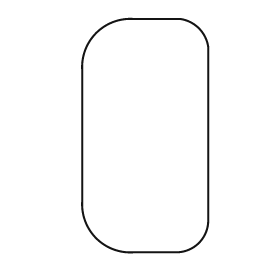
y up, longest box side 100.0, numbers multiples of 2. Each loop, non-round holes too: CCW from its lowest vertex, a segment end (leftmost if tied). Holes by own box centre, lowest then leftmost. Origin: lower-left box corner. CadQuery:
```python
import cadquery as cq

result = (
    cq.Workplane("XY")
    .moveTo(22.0, 0.0)
    .lineTo(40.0, 0.0)
    .threePointArc((50.0, 4.0), (54.0, 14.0))
    .lineTo(54.0, 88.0)
    .threePointArc((50.0, 96.0), (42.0, 100.0))
    .lineTo(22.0, 100.0)
    .threePointArc((6.0, 94.0), (0.0, 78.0))
    .lineTo(0.0, 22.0)
    .threePointArc((6.0, 6.0), (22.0, 0.0))
    .close()
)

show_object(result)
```